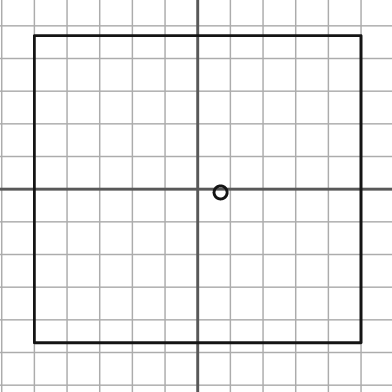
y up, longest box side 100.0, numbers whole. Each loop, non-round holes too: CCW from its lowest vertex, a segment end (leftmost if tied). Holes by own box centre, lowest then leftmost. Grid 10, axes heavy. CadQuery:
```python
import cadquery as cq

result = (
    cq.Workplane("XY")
    .moveTo(-50.0, -47.0)
    .lineTo(50.0, -47.0)
    .lineTo(50.0, 47.0)
    .lineTo(-50.0, 47.0)
    .close()
    .moveTo(7.0, -1.0)
    .circle(2.0)
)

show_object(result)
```